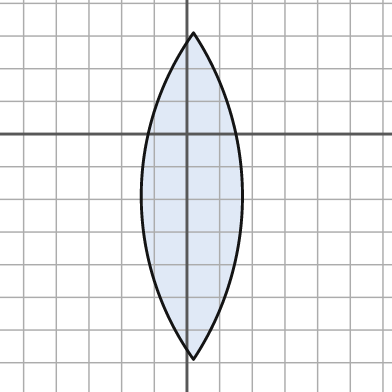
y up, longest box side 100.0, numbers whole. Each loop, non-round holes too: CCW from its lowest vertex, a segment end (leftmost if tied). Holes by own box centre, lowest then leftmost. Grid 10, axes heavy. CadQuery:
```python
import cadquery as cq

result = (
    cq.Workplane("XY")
    .moveTo(2.0, -69.0)
    .threePointArc((17.0, -19.0), (2.0, 31.0))
    .threePointArc((-14.0, -19.0), (2.0, -69.0))
    .close()
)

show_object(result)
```